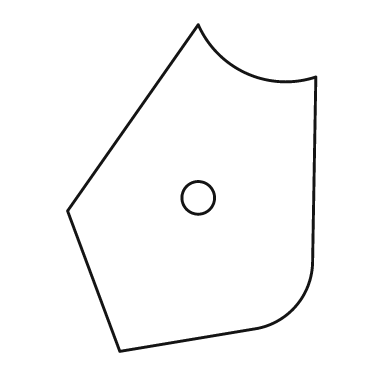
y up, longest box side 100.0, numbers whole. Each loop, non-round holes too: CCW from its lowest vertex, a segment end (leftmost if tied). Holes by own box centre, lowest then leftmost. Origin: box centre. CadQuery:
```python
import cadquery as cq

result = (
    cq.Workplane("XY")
    .moveTo(-22.0, -50.0)
    .lineTo(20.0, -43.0)
    .threePointArc((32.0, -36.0), (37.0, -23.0))
    .lineTo(38.0, 34.0)
    .threePointArc((17.0, 35.0), (2.0, 50.0))
    .lineTo(-38.0, -7.0)
    .close()
    .moveTo(2.0, -3.0)
    .circle(5.0)
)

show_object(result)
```